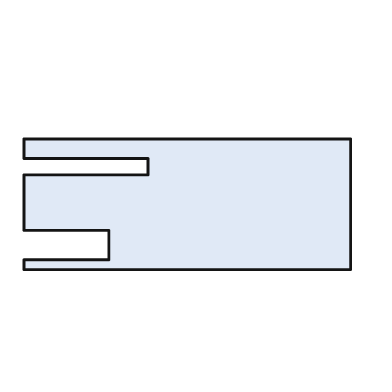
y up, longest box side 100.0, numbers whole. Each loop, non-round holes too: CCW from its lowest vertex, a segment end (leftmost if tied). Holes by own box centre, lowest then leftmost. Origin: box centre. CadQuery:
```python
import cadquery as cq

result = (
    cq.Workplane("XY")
    .moveTo(-50.0, -20.0)
    .lineTo(50.0, -20.0)
    .lineTo(50.0, 20.0)
    .lineTo(-50.0, 20.0)
    .lineTo(-50.0, 14.0)
    .lineTo(-12.0, 14.0)
    .lineTo(-12.0, 9.0)
    .lineTo(-50.0, 9.0)
    .lineTo(-50.0, -8.0)
    .lineTo(-24.0, -8.0)
    .lineTo(-24.0, -17.0)
    .lineTo(-50.0, -17.0)
    .close()
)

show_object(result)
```